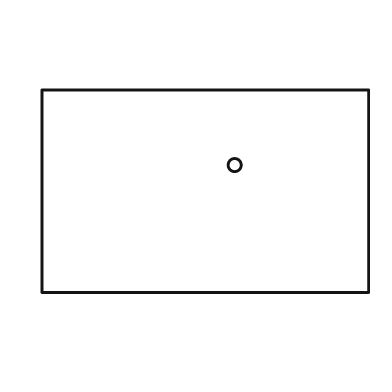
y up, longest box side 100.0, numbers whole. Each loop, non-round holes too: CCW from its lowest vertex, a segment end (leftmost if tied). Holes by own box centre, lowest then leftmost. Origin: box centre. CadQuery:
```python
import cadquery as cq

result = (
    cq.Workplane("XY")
    .moveTo(-50.0, -31.0)
    .lineTo(50.0, -31.0)
    .lineTo(50.0, 31.0)
    .lineTo(-50.0, 31.0)
    .close()
    .moveTo(9.0, 8.0)
    .circle(2.0)
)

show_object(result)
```